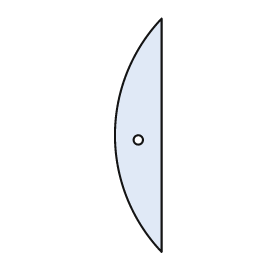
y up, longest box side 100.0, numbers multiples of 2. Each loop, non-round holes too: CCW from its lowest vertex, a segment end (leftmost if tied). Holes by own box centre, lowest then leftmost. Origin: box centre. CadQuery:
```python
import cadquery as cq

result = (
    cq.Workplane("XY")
    .moveTo(10.0, -50.0)
    .lineTo(10.0, 50.0)
    .threePointArc((-10.0, 0.0), (10.0, -50.0))
    .close()
    .moveTo(0.0, -2.0)
    .circle(2.0)
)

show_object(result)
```